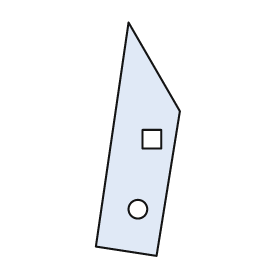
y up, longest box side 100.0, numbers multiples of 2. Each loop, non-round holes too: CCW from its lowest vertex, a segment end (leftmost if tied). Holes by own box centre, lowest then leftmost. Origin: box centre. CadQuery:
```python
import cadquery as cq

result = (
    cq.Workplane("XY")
    .moveTo(8.0, -50.0)
    .lineTo(18.0, 12.0)
    .lineTo(-4.0, 50.0)
    .lineTo(-18.0, -46.0)
    .close()
    .moveTo(0.0, -30.0)
    .circle(4.0)
    .moveTo(2.0, -4.0)
    .lineTo(10.0, -4.0)
    .lineTo(10.0, 4.0)
    .lineTo(2.0, 4.0)
    .close()
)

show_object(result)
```